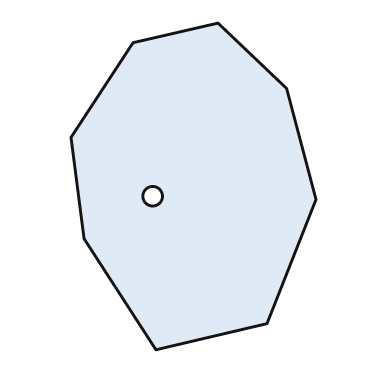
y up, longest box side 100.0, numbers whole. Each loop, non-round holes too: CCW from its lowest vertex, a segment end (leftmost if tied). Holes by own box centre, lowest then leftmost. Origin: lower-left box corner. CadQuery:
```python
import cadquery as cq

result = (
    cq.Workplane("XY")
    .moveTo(26.0, 0.0)
    .lineTo(60.0, 8.0)
    .lineTo(75.0, 46.0)
    .lineTo(66.0, 80.0)
    .lineTo(45.0, 100.0)
    .lineTo(19.0, 94.0)
    .lineTo(0.0, 65.0)
    .lineTo(4.0, 34.0)
    .close()
    .moveTo(25.0, 47.0)
    .circle(3.0)
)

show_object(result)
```